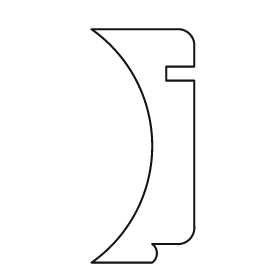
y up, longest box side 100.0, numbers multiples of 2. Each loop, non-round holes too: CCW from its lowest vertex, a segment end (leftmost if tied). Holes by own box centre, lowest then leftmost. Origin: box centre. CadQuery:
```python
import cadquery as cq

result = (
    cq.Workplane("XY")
    .moveTo(-22.0, -50.0)
    .lineTo(4.0, -50.0)
    .threePointArc((6.0, -46.0), (4.0, -42.0))
    .lineTo(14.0, -42.0)
    .threePointArc((20.0, -40.0), (22.0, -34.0))
    .lineTo(22.0, 28.0)
    .lineTo(10.0, 28.0)
    .lineTo(10.0, 34.0)
    .lineTo(22.0, 34.0)
    .lineTo(22.0, 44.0)
    .threePointArc((20.0, 48.0), (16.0, 50.0))
    .lineTo(-22.0, 50.0)
    .threePointArc((4.0, 0.0), (-22.0, -50.0))
    .close()
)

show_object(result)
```